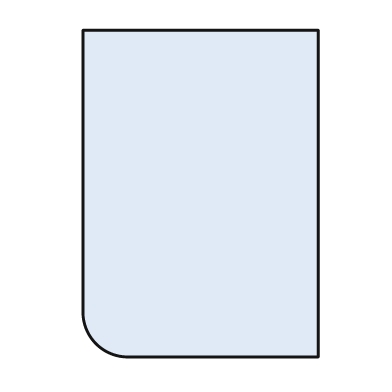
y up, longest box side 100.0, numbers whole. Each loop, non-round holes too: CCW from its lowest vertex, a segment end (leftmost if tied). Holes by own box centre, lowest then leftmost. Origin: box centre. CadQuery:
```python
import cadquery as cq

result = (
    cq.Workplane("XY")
    .moveTo(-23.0, -50.0)
    .lineTo(36.0, -50.0)
    .lineTo(36.0, 50.0)
    .lineTo(-36.0, 50.0)
    .lineTo(-36.0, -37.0)
    .threePointArc((-32.0, -46.0), (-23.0, -50.0))
    .close()
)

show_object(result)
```